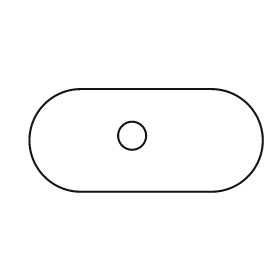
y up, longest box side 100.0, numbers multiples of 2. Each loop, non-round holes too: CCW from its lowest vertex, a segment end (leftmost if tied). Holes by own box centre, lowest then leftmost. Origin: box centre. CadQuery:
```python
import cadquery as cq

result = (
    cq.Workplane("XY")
    .moveTo(-28.0, -22.0)
    .lineTo(28.0, -22.0)
    .threePointArc((50.0, 0.0), (28.0, 22.0))
    .lineTo(-28.0, 22.0)
    .threePointArc((-50.0, 0.0), (-28.0, -22.0))
    .close()
    .moveTo(-6.0, 2.0)
    .circle(6.0)
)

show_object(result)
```